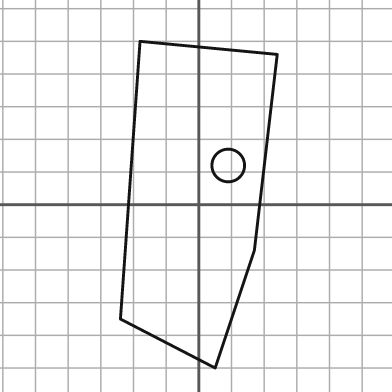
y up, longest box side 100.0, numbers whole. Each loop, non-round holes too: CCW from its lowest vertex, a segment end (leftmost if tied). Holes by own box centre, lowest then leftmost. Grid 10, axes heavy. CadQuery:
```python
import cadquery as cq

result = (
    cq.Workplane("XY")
    .moveTo(5.0, -50.0)
    .lineTo(17.0, -14.0)
    .lineTo(24.0, 46.0)
    .lineTo(-18.0, 50.0)
    .lineTo(-24.0, -35.0)
    .close()
    .moveTo(9.0, 12.0)
    .circle(5.0)
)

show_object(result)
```